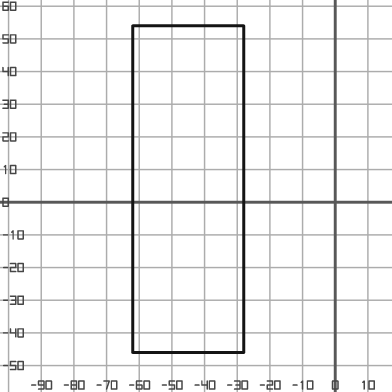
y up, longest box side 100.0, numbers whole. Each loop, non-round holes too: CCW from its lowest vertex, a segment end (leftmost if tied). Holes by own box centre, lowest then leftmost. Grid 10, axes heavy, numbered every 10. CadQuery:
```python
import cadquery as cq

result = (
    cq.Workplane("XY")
    .moveTo(-62.0, -46.0)
    .lineTo(-28.0, -46.0)
    .lineTo(-28.0, 54.0)
    .lineTo(-62.0, 54.0)
    .close()
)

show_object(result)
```